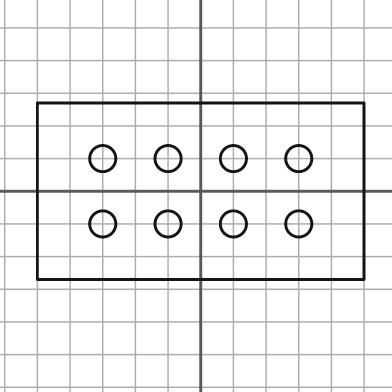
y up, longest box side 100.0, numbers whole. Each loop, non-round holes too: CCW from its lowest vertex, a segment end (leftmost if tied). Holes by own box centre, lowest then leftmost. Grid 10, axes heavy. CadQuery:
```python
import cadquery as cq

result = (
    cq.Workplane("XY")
    .moveTo(-50.0, -27.0)
    .lineTo(50.0, -27.0)
    .lineTo(50.0, 27.0)
    .lineTo(-50.0, 27.0)
    .close()
    .moveTo(-30.0, -10.0)
    .circle(4.0)
    .moveTo(-10.0, -10.0)
    .circle(4.0)
    .moveTo(10.0, -10.0)
    .circle(4.0)
    .moveTo(30.0, -10.0)
    .circle(4.0)
    .moveTo(-30.0, 10.0)
    .circle(4.0)
    .moveTo(-10.0, 10.0)
    .circle(4.0)
    .moveTo(10.0, 10.0)
    .circle(4.0)
    .moveTo(30.0, 10.0)
    .circle(4.0)
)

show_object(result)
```